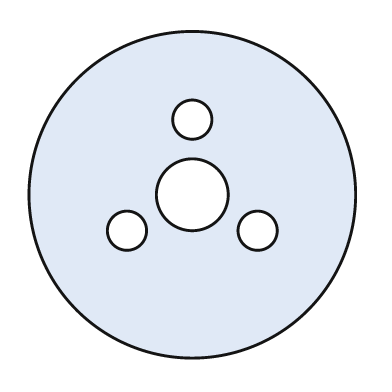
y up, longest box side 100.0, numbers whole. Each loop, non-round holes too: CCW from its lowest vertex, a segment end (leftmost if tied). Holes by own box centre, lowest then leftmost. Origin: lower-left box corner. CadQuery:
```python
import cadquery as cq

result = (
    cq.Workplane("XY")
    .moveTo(50.0, 50.0)
    .circle(50.0)
    .moveTo(30.0, 39.0)
    .circle(6.0)
    .moveTo(70.0, 39.0)
    .circle(6.0)
    .moveTo(50.0, 50.0)
    .circle(11.0)
    .moveTo(50.0, 73.0)
    .circle(6.0)
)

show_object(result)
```